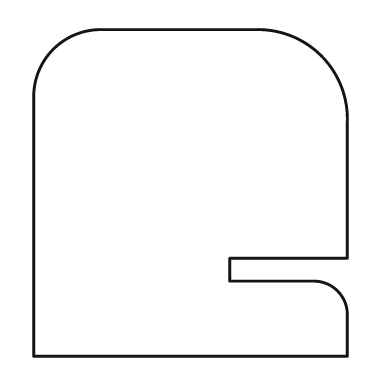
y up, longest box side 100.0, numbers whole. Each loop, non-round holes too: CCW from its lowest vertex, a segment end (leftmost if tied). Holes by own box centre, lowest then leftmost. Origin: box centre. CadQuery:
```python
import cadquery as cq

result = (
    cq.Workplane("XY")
    .moveTo(-48.0, -50.0)
    .lineTo(48.0, -50.0)
    .lineTo(48.0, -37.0)
    .threePointArc((45.0, -30.0), (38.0, -27.0))
    .lineTo(12.0, -27.0)
    .lineTo(12.0, -20.0)
    .lineTo(48.0, -20.0)
    .lineTo(48.0, 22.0)
    .threePointArc((40.0, 42.0), (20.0, 50.0))
    .lineTo(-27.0, 50.0)
    .threePointArc((-42.0, 44.0), (-48.0, 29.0))
    .close()
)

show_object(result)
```